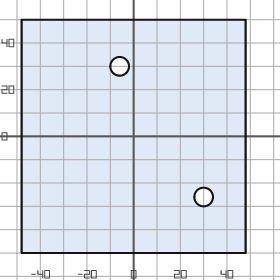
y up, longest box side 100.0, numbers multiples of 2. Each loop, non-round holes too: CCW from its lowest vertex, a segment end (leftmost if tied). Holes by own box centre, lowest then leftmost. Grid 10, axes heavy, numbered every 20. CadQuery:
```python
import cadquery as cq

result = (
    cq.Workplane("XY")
    .moveTo(-48.0, -50.0)
    .lineTo(48.0, -50.0)
    .lineTo(48.0, 50.0)
    .lineTo(-48.0, 50.0)
    .close()
    .moveTo(30.0, -26.0)
    .circle(4.0)
    .moveTo(-6.0, 30.0)
    .circle(4.0)
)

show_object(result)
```